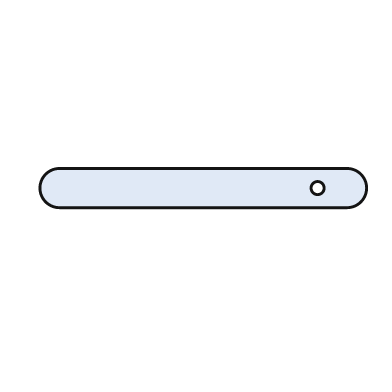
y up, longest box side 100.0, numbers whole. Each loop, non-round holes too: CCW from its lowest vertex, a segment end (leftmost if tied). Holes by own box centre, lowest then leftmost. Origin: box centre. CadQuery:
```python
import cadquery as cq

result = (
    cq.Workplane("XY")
    .moveTo(-44.0, -6.0)
    .lineTo(44.0, -6.0)
    .threePointArc((50.0, 0.0), (44.0, 6.0))
    .lineTo(-44.0, 6.0)
    .threePointArc((-50.0, 0.0), (-44.0, -6.0))
    .close()
    .moveTo(35.0, 0.0)
    .circle(2.0)
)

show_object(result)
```